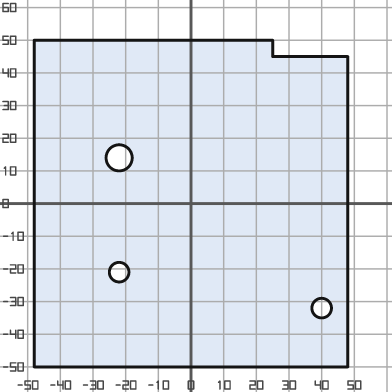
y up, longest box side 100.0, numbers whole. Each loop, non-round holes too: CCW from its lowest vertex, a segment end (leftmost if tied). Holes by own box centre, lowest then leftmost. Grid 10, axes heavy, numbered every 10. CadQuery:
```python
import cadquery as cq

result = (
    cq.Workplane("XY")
    .moveTo(-48.0, -50.0)
    .lineTo(48.0, -50.0)
    .lineTo(48.0, 45.0)
    .lineTo(25.0, 45.0)
    .lineTo(25.0, 50.0)
    .lineTo(-48.0, 50.0)
    .close()
    .moveTo(40.0, -32.0)
    .circle(3.0)
    .moveTo(-22.0, -21.0)
    .circle(3.0)
    .moveTo(-22.0, 14.0)
    .circle(4.0)
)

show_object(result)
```